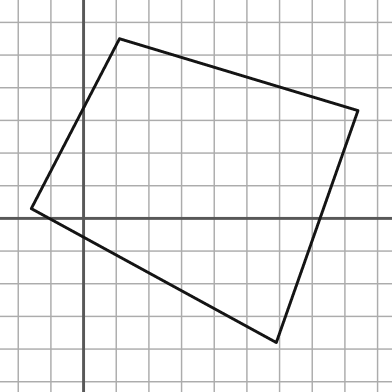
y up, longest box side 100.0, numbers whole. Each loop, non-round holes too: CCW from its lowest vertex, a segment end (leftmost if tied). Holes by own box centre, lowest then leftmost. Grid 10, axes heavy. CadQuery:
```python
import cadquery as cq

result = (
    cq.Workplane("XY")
    .moveTo(59.0, -38.0)
    .lineTo(84.0, 33.0)
    .lineTo(11.0, 55.0)
    .lineTo(-16.0, 3.0)
    .close()
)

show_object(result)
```